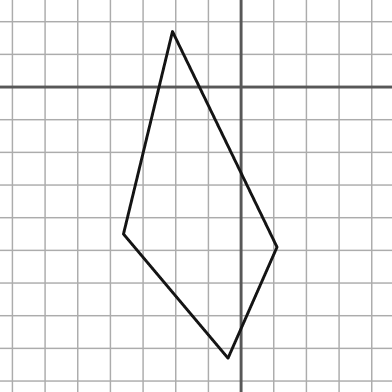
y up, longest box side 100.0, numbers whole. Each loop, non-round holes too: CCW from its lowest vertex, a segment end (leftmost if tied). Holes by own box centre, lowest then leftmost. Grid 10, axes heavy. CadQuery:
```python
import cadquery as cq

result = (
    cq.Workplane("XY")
    .moveTo(-4.0, -83.0)
    .lineTo(11.0, -49.0)
    .lineTo(-21.0, 17.0)
    .lineTo(-36.0, -45.0)
    .close()
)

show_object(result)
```